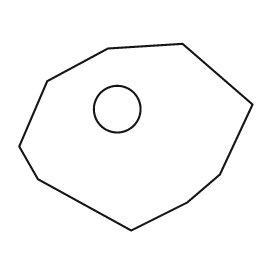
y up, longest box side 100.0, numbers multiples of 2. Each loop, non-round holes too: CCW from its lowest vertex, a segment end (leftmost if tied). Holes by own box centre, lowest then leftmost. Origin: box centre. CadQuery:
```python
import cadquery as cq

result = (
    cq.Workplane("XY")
    .moveTo(-2.0, -40.0)
    .lineTo(22.0, -28.0)
    .lineTo(36.0, -16.0)
    .lineTo(50.0, 14.0)
    .lineTo(20.0, 40.0)
    .lineTo(-12.0, 38.0)
    .lineTo(-38.0, 24.0)
    .lineTo(-50.0, -4.0)
    .lineTo(-42.0, -18.0)
    .close()
    .moveTo(-8.0, 12.0)
    .circle(10.0)
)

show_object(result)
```